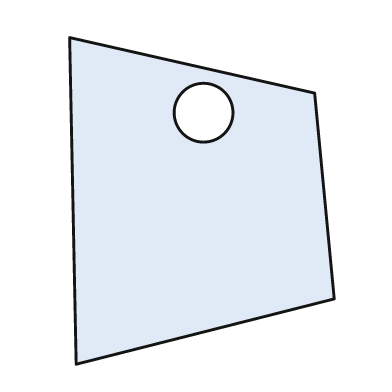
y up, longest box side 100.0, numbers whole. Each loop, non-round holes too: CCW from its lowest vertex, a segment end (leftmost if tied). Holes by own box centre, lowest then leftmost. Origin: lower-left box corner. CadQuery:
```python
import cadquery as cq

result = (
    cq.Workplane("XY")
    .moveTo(2.0, 0.0)
    .lineTo(81.0, 20.0)
    .lineTo(75.0, 83.0)
    .lineTo(0.0, 100.0)
    .close()
    .moveTo(41.0, 77.0)
    .circle(9.0)
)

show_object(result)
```